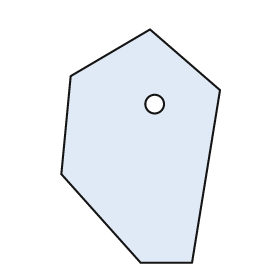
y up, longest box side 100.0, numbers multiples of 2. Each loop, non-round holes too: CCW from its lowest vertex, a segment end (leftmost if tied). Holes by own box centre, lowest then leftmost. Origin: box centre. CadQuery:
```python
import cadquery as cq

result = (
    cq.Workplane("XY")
    .moveTo(0.0, -50.0)
    .lineTo(22.0, -50.0)
    .lineTo(34.0, 24.0)
    .lineTo(4.0, 50.0)
    .lineTo(-30.0, 30.0)
    .lineTo(-34.0, -12.0)
    .close()
    .moveTo(6.0, 18.0)
    .circle(4.0)
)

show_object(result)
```